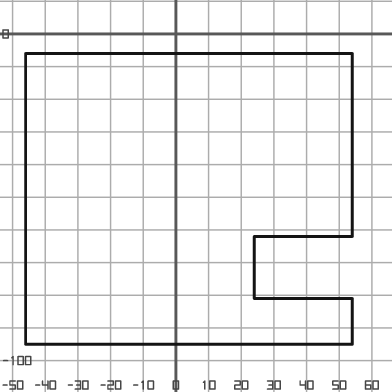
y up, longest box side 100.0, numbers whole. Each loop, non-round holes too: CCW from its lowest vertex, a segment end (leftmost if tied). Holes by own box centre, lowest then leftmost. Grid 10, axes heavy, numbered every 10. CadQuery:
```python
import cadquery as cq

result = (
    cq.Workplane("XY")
    .moveTo(-46.0, -95.0)
    .lineTo(54.0, -95.0)
    .lineTo(54.0, -81.0)
    .lineTo(24.0, -81.0)
    .lineTo(24.0, -62.0)
    .lineTo(54.0, -62.0)
    .lineTo(54.0, -6.0)
    .lineTo(-46.0, -6.0)
    .close()
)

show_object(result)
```